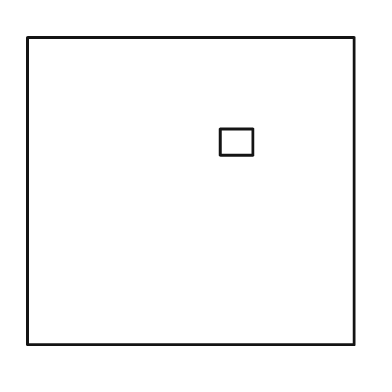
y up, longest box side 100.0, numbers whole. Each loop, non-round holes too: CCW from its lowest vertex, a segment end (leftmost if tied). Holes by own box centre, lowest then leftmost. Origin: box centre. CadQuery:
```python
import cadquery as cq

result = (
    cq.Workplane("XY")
    .moveTo(-50.0, -47.0)
    .lineTo(50.0, -47.0)
    .lineTo(50.0, 47.0)
    .lineTo(-50.0, 47.0)
    .close()
    .moveTo(9.0, 11.0)
    .lineTo(19.0, 11.0)
    .lineTo(19.0, 19.0)
    .lineTo(9.0, 19.0)
    .close()
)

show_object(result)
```